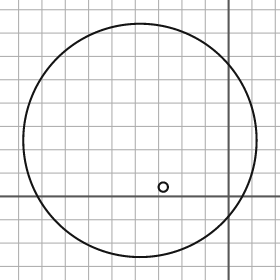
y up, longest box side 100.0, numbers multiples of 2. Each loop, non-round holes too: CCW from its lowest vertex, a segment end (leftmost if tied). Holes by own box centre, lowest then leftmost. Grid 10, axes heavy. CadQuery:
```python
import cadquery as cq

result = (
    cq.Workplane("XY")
    .moveTo(-38.0, 24.0)
    .circle(50.0)
    .moveTo(-28.0, 4.0)
    .circle(2.0)
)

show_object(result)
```